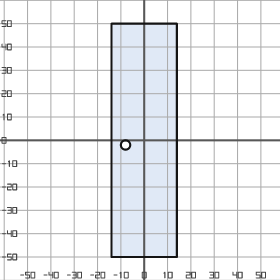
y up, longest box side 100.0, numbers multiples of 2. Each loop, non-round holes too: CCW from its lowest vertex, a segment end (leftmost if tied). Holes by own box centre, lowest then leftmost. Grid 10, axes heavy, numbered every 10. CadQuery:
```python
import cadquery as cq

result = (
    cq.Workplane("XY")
    .moveTo(-14.0, -50.0)
    .lineTo(14.0, -50.0)
    .lineTo(14.0, 50.0)
    .lineTo(-14.0, 50.0)
    .close()
    .moveTo(-8.0, -2.0)
    .circle(2.0)
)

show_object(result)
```